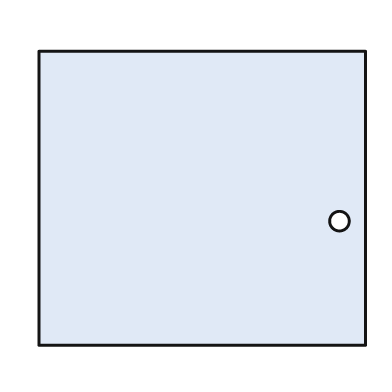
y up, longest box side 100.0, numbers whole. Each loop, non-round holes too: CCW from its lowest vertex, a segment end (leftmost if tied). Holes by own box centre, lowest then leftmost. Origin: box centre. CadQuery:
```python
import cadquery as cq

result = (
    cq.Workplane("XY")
    .moveTo(-50.0, -45.0)
    .lineTo(50.0, -45.0)
    .lineTo(50.0, 45.0)
    .lineTo(-50.0, 45.0)
    .close()
    .moveTo(42.0, -7.0)
    .circle(3.0)
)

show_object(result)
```